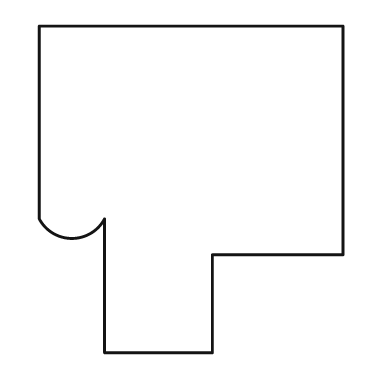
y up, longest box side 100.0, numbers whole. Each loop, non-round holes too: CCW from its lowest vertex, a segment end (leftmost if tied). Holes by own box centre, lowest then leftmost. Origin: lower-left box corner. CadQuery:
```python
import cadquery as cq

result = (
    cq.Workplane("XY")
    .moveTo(20.0, 0.0)
    .lineTo(53.0, 0.0)
    .lineTo(53.0, 30.0)
    .lineTo(93.0, 30.0)
    .lineTo(93.0, 100.0)
    .lineTo(0.0, 100.0)
    .lineTo(0.0, 41.0)
    .threePointArc((10.0, 35.0), (20.0, 41.0))
    .close()
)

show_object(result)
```